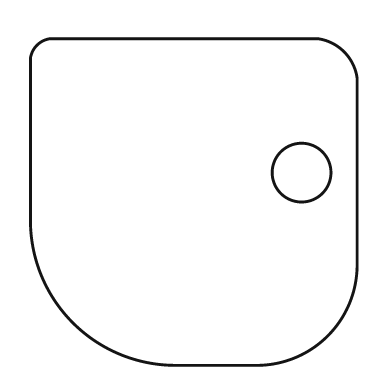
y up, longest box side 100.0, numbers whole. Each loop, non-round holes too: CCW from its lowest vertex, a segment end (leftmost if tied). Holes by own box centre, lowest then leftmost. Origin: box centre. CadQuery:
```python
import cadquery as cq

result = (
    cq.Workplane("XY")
    .moveTo(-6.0, -50.0)
    .lineTo(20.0, -50.0)
    .threePointArc((41.0, -41.0), (50.0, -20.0))
    .lineTo(50.0, 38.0)
    .threePointArc((46.0, 46.0), (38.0, 50.0))
    .lineTo(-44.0, 50.0)
    .threePointArc((-48.0, 48.0), (-50.0, 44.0))
    .lineTo(-50.0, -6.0)
    .threePointArc((-37.0, -37.0), (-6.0, -50.0))
    .close()
    .moveTo(33.0, 9.0)
    .circle(9.0)
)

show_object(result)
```